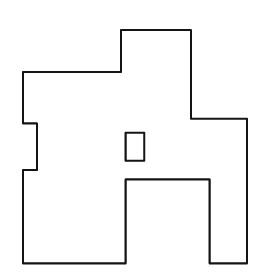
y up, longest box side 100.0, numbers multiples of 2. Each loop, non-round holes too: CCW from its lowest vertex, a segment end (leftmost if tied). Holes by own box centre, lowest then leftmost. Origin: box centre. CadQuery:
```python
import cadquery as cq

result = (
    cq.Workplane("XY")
    .moveTo(-48.0, -50.0)
    .lineTo(-4.0, -50.0)
    .lineTo(-4.0, -14.0)
    .lineTo(32.0, -14.0)
    .lineTo(32.0, -50.0)
    .lineTo(48.0, -50.0)
    .lineTo(48.0, 12.0)
    .lineTo(24.0, 12.0)
    .lineTo(24.0, 50.0)
    .lineTo(-6.0, 50.0)
    .lineTo(-6.0, 32.0)
    .lineTo(-48.0, 32.0)
    .lineTo(-48.0, 10.0)
    .lineTo(-42.0, 10.0)
    .lineTo(-42.0, -10.0)
    .lineTo(-48.0, -10.0)
    .close()
    .moveTo(-4.0, -6.0)
    .lineTo(4.0, -6.0)
    .lineTo(4.0, 6.0)
    .lineTo(-4.0, 6.0)
    .close()
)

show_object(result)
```